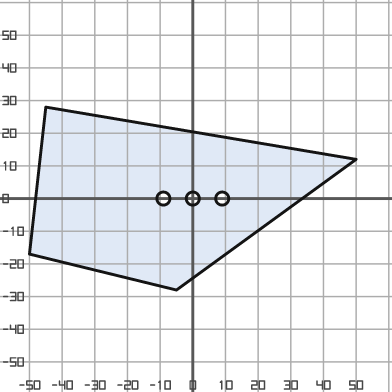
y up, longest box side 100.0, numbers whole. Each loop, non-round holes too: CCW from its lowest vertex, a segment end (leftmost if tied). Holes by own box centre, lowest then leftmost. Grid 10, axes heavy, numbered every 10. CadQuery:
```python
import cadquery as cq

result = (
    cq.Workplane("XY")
    .moveTo(-5.0, -28.0)
    .lineTo(50.0, 12.0)
    .lineTo(-45.0, 28.0)
    .lineTo(-50.0, -17.0)
    .close()
    .moveTo(-9.0, 0.0)
    .circle(2.0)
    .moveTo(0.0, 0.0)
    .circle(2.0)
    .moveTo(9.0, 0.0)
    .circle(2.0)
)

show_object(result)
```